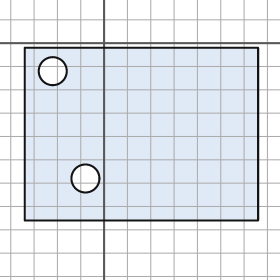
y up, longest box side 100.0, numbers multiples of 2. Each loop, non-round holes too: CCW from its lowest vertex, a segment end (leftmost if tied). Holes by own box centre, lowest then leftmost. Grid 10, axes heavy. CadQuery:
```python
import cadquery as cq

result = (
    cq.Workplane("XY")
    .moveTo(-34.0, -76.0)
    .lineTo(66.0, -76.0)
    .lineTo(66.0, -2.0)
    .lineTo(-34.0, -2.0)
    .close()
    .moveTo(-8.0, -58.0)
    .circle(6.0)
    .moveTo(-22.0, -12.0)
    .circle(6.0)
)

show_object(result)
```